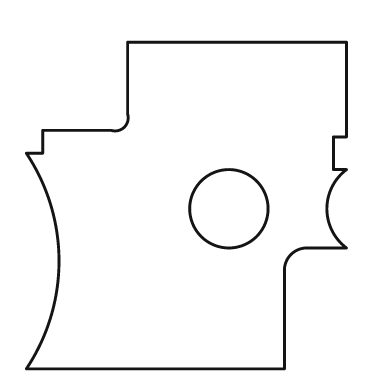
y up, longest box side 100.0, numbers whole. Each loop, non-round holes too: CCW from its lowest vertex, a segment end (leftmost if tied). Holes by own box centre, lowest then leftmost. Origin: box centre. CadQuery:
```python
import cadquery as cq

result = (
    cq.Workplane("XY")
    .moveTo(-49.0, -50.0)
    .lineTo(30.0, -50.0)
    .lineTo(30.0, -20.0)
    .threePointArc((32.0, -15.0), (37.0, -13.0))
    .lineTo(49.0, -13.0)
    .threePointArc((43.0, -1.0), (49.0, 11.0))
    .lineTo(45.0, 11.0)
    .lineTo(45.0, 21.0)
    .lineTo(49.0, 21.0)
    .lineTo(49.0, 50.0)
    .lineTo(-18.0, 50.0)
    .lineTo(-18.0, 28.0)
    .threePointArc((-19.0, 24.0), (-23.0, 23.0))
    .lineTo(-44.0, 23.0)
    .lineTo(-44.0, 16.0)
    .lineTo(-49.0, 16.0)
    .threePointArc((-39.0, -17.0), (-49.0, -50.0))
    .close()
    .moveTo(13.0, -1.0)
    .circle(12.0)
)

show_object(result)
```